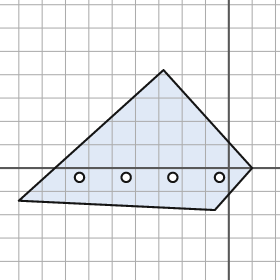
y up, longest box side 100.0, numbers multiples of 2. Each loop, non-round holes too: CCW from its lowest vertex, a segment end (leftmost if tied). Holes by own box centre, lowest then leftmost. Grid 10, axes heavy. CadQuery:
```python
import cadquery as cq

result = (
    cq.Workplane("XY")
    .moveTo(-6.0, -18.0)
    .lineTo(10.0, 0.0)
    .lineTo(-28.0, 42.0)
    .lineTo(-90.0, -14.0)
    .close()
    .moveTo(-64.0, -4.0)
    .circle(2.0)
    .moveTo(-44.0, -4.0)
    .circle(2.0)
    .moveTo(-24.0, -4.0)
    .circle(2.0)
    .moveTo(-4.0, -4.0)
    .circle(2.0)
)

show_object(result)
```